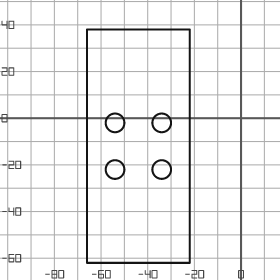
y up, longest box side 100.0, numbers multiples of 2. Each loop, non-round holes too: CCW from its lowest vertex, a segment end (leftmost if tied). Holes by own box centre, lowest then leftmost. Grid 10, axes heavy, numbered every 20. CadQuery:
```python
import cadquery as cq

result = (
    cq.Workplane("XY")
    .moveTo(-66.0, -62.0)
    .lineTo(-22.0, -62.0)
    .lineTo(-22.0, 38.0)
    .lineTo(-66.0, 38.0)
    .close()
    .moveTo(-54.0, -22.0)
    .circle(4.0)
    .moveTo(-34.0, -22.0)
    .circle(4.0)
    .moveTo(-54.0, -2.0)
    .circle(4.0)
    .moveTo(-34.0, -2.0)
    .circle(4.0)
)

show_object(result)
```